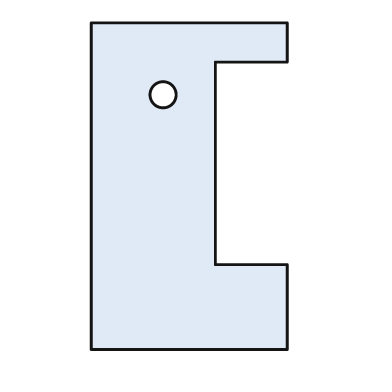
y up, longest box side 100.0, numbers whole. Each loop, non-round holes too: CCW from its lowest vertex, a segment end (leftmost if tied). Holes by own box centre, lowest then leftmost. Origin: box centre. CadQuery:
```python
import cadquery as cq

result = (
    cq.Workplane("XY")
    .moveTo(-30.0, -50.0)
    .lineTo(30.0, -50.0)
    .lineTo(30.0, -24.0)
    .lineTo(8.0, -24.0)
    .lineTo(8.0, 38.0)
    .lineTo(30.0, 38.0)
    .lineTo(30.0, 50.0)
    .lineTo(-30.0, 50.0)
    .close()
    .moveTo(-8.0, 28.0)
    .circle(4.0)
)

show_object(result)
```